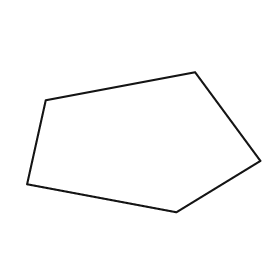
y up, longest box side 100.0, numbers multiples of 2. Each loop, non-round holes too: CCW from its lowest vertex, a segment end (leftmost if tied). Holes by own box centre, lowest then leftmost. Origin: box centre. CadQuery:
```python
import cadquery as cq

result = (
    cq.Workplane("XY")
    .moveTo(14.0, -30.0)
    .lineTo(50.0, -8.0)
    .lineTo(22.0, 30.0)
    .lineTo(-42.0, 18.0)
    .lineTo(-50.0, -18.0)
    .close()
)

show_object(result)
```